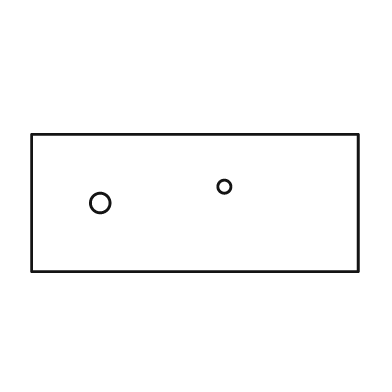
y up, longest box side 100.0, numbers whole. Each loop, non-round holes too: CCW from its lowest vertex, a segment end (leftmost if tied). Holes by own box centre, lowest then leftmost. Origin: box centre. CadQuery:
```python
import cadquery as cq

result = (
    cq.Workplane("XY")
    .moveTo(-50.0, -21.0)
    .lineTo(50.0, -21.0)
    .lineTo(50.0, 21.0)
    .lineTo(-50.0, 21.0)
    .close()
    .moveTo(-29.0, 0.0)
    .circle(3.0)
    .moveTo(9.0, 5.0)
    .circle(2.0)
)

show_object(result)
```